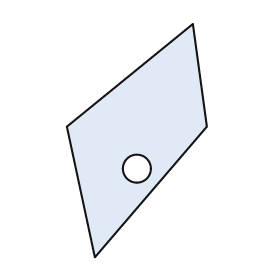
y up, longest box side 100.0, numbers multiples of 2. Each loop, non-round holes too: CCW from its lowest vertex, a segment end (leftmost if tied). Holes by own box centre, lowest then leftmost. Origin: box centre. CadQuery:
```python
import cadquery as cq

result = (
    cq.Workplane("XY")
    .moveTo(-18.0, -50.0)
    .lineTo(30.0, 6.0)
    .lineTo(24.0, 50.0)
    .lineTo(-30.0, 6.0)
    .close()
    .moveTo(0.0, -12.0)
    .circle(6.0)
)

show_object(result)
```